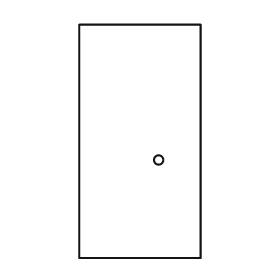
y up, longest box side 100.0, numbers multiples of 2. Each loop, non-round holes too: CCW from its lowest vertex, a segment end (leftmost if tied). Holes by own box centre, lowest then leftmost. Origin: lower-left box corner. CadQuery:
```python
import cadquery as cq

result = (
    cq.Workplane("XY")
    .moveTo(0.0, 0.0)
    .lineTo(52.0, 0.0)
    .lineTo(52.0, 100.0)
    .lineTo(0.0, 100.0)
    .close()
    .moveTo(34.0, 42.0)
    .circle(2.0)
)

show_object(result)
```